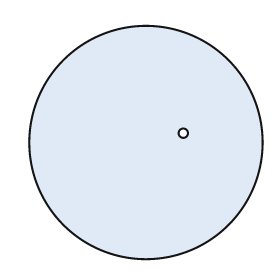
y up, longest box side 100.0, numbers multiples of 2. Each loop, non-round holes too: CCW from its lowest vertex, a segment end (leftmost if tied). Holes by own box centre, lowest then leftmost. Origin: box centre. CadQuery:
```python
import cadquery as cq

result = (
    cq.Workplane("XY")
    .moveTo(0.0, 0.0)
    .circle(50.0)
    .moveTo(16.0, 4.0)
    .circle(2.0)
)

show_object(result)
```